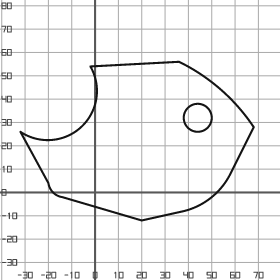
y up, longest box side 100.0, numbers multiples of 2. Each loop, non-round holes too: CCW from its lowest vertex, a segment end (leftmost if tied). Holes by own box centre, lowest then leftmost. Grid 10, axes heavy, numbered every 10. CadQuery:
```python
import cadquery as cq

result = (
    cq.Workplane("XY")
    .moveTo(20.0, -12.0)
    .lineTo(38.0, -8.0)
    .threePointArc((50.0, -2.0), (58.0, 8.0))
    .lineTo(68.0, 28.0)
    .threePointArc((54.0, 44.0), (36.0, 56.0))
    .lineTo(-2.0, 54.0)
    .threePointArc((-6.0, 28.0), (-32.0, 26.0))
    .lineTo(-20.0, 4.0)
    .threePointArc((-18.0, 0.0), (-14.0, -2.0))
    .close()
    .moveTo(44.0, 32.0)
    .circle(6.0)
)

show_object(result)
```